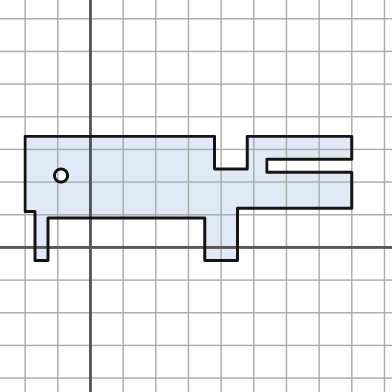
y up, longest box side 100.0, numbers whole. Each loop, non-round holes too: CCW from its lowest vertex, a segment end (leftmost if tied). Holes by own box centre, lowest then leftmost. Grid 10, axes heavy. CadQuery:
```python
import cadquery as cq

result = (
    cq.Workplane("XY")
    .moveTo(-17.0, -4.0)
    .lineTo(-13.0, -4.0)
    .lineTo(-13.0, 9.0)
    .lineTo(35.0, 9.0)
    .lineTo(35.0, -4.0)
    .lineTo(45.0, -4.0)
    .lineTo(45.0, 12.0)
    .lineTo(80.0, 12.0)
    .lineTo(80.0, 23.0)
    .lineTo(54.0, 23.0)
    .lineTo(54.0, 27.0)
    .lineTo(80.0, 27.0)
    .lineTo(80.0, 34.0)
    .lineTo(48.0, 34.0)
    .lineTo(48.0, 24.0)
    .lineTo(38.0, 24.0)
    .lineTo(38.0, 34.0)
    .lineTo(-20.0, 34.0)
    .lineTo(-20.0, 11.0)
    .lineTo(-17.0, 11.0)
    .close()
    .moveTo(-9.0, 22.0)
    .circle(2.0)
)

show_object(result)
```